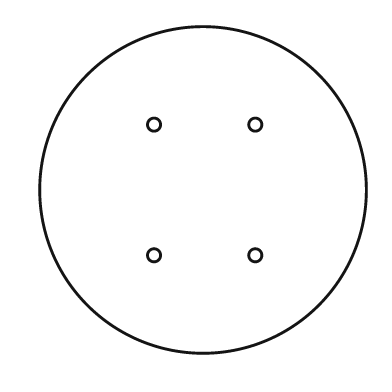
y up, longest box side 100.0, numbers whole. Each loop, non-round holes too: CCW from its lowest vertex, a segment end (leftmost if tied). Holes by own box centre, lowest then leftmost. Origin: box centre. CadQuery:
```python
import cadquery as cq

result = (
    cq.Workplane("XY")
    .moveTo(0.0, 0.0)
    .circle(50.0)
    .moveTo(-15.0, -20.0)
    .circle(2.0)
    .moveTo(16.0, -20.0)
    .circle(2.0)
    .moveTo(-15.0, 20.0)
    .circle(2.0)
    .moveTo(16.0, 20.0)
    .circle(2.0)
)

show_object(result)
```